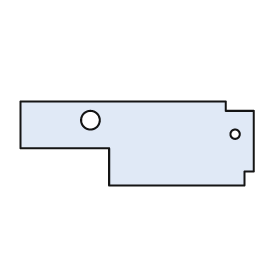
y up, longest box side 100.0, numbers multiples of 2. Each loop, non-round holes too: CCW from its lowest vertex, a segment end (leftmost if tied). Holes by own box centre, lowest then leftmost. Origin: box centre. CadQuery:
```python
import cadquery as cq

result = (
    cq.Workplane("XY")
    .moveTo(-12.0, -18.0)
    .lineTo(46.0, -18.0)
    .lineTo(46.0, -12.0)
    .lineTo(50.0, -12.0)
    .lineTo(50.0, 14.0)
    .lineTo(38.0, 14.0)
    .lineTo(38.0, 18.0)
    .lineTo(-50.0, 18.0)
    .lineTo(-50.0, -2.0)
    .lineTo(-12.0, -2.0)
    .close()
    .moveTo(42.0, 4.0)
    .circle(2.0)
    .moveTo(-20.0, 10.0)
    .circle(4.0)
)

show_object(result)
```